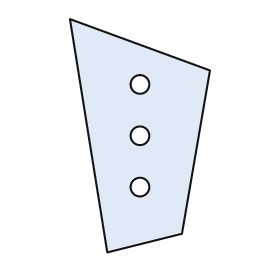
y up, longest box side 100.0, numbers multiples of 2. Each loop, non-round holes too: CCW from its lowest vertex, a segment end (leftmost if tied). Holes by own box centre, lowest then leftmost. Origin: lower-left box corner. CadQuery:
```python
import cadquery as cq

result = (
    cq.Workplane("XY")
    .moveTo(16.0, 0.0)
    .lineTo(48.0, 8.0)
    .lineTo(60.0, 78.0)
    .lineTo(0.0, 100.0)
    .close()
    .moveTo(30.0, 28.0)
    .circle(4.0)
    .moveTo(30.0, 50.0)
    .circle(4.0)
    .moveTo(30.0, 72.0)
    .circle(4.0)
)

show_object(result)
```